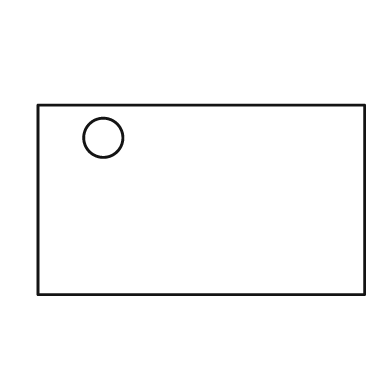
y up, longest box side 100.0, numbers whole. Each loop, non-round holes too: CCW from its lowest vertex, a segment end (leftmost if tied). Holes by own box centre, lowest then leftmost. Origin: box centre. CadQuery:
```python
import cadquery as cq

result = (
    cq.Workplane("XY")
    .moveTo(-50.0, -29.0)
    .lineTo(50.0, -29.0)
    .lineTo(50.0, 29.0)
    .lineTo(-50.0, 29.0)
    .close()
    .moveTo(-30.0, 19.0)
    .circle(6.0)
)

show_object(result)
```